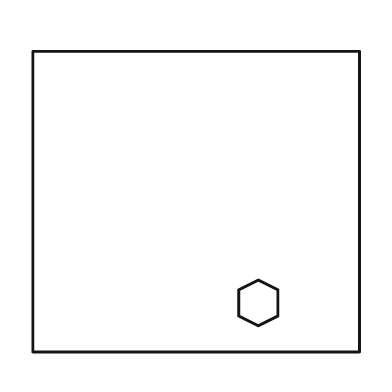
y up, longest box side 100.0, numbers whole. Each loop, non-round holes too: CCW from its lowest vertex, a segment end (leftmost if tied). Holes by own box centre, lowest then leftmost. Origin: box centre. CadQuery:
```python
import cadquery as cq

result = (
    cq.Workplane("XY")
    .moveTo(-50.0, -46.0)
    .lineTo(50.0, -46.0)
    .lineTo(50.0, 46.0)
    .lineTo(-50.0, 46.0)
    .close()
    .moveTo(19.0, -38.0)
    .lineTo(25.0, -35.0)
    .lineTo(25.0, -27.0)
    .lineTo(19.0, -24.0)
    .lineTo(13.0, -27.0)
    .lineTo(13.0, -35.0)
    .close()
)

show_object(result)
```